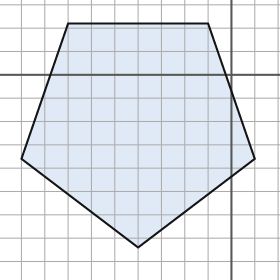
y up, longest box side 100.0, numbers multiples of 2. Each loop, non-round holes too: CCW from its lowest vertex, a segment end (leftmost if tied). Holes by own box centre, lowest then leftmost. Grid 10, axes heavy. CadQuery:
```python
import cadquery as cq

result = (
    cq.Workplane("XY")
    .moveTo(-40.0, -74.0)
    .lineTo(10.0, -36.0)
    .lineTo(-10.0, 22.0)
    .lineTo(-70.0, 22.0)
    .lineTo(-90.0, -36.0)
    .close()
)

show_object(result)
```